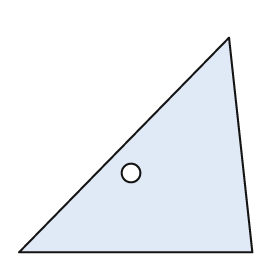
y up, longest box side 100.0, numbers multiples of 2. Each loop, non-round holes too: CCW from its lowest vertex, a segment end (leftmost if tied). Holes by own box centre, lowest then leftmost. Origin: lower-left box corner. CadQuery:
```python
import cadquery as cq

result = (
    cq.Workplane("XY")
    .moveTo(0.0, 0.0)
    .lineTo(100.0, 0.0)
    .lineTo(90.0, 92.0)
    .close()
    .moveTo(48.0, 34.0)
    .circle(4.0)
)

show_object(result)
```